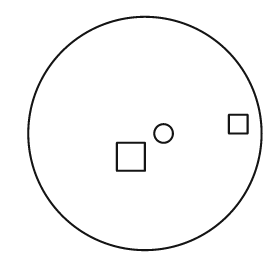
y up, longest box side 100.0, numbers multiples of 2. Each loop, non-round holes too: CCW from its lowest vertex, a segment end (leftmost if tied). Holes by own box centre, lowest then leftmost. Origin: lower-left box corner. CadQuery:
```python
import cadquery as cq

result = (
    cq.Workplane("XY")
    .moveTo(50.0, 50.0)
    .circle(50.0)
    .moveTo(38.0, 34.0)
    .lineTo(50.0, 34.0)
    .lineTo(50.0, 46.0)
    .lineTo(38.0, 46.0)
    .close()
    .moveTo(58.0, 50.0)
    .circle(4.0)
    .moveTo(86.0, 50.0)
    .lineTo(94.0, 50.0)
    .lineTo(94.0, 58.0)
    .lineTo(86.0, 58.0)
    .close()
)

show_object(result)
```